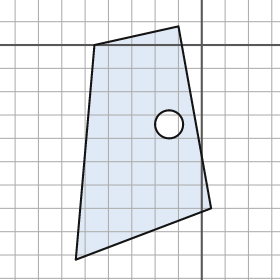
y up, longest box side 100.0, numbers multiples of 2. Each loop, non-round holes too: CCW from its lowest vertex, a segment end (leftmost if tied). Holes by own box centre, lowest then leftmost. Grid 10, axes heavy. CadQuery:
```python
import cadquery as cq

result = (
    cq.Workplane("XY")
    .moveTo(-54.0, -92.0)
    .lineTo(4.0, -70.0)
    .lineTo(-10.0, 8.0)
    .lineTo(-46.0, 0.0)
    .close()
    .moveTo(-14.0, -34.0)
    .circle(6.0)
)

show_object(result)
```